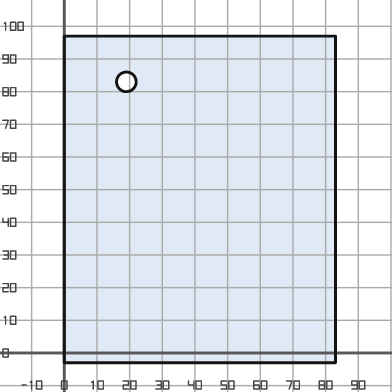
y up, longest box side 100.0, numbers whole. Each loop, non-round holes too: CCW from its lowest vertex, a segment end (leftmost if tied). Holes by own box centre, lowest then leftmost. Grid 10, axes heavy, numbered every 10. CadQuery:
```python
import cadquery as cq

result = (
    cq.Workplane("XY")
    .moveTo(0.0, -3.0)
    .lineTo(83.0, -3.0)
    .lineTo(83.0, 97.0)
    .lineTo(0.0, 97.0)
    .close()
    .moveTo(19.0, 83.0)
    .circle(3.0)
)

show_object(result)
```